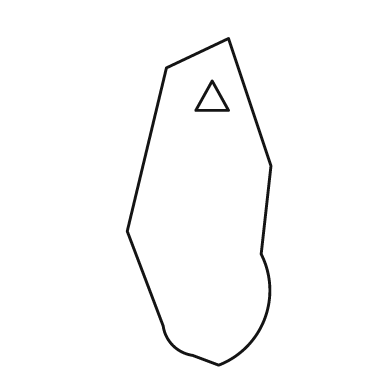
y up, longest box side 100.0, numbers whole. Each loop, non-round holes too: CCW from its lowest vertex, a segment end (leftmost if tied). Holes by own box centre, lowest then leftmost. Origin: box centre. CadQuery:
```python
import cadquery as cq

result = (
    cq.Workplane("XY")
    .moveTo(6.0, -50.0)
    .threePointArc((20.0, -36.0), (19.0, -16.0))
    .lineTo(22.0, 11.0)
    .lineTo(9.0, 50.0)
    .lineTo(-10.0, 41.0)
    .lineTo(-22.0, -9.0)
    .lineTo(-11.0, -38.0)
    .threePointArc((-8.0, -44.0), (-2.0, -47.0))
    .close()
    .moveTo(-1.0, 28.0)
    .lineTo(9.0, 28.0)
    .lineTo(4.0, 37.0)
    .close()
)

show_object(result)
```